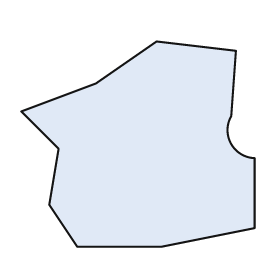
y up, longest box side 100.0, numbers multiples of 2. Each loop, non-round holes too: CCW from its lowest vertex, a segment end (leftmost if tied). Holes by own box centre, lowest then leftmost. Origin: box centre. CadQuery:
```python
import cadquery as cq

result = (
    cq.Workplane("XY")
    .moveTo(-26.0, -44.0)
    .lineTo(10.0, -44.0)
    .lineTo(50.0, -36.0)
    .lineTo(50.0, -6.0)
    .threePointArc((40.0, 0.0), (40.0, 12.0))
    .lineTo(42.0, 40.0)
    .lineTo(8.0, 44.0)
    .lineTo(-18.0, 26.0)
    .lineTo(-50.0, 14.0)
    .lineTo(-34.0, -2.0)
    .lineTo(-38.0, -26.0)
    .close()
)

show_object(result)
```